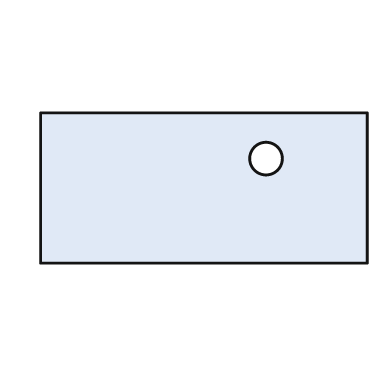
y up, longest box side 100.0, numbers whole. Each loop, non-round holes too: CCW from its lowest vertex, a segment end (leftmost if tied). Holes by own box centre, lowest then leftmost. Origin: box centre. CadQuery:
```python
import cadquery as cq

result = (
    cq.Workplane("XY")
    .moveTo(-50.0, -23.0)
    .lineTo(50.0, -23.0)
    .lineTo(50.0, 23.0)
    .lineTo(-50.0, 23.0)
    .close()
    .moveTo(19.0, 9.0)
    .circle(5.0)
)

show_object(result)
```